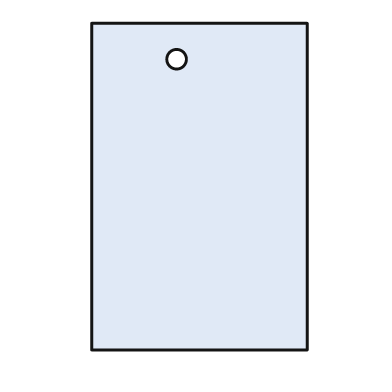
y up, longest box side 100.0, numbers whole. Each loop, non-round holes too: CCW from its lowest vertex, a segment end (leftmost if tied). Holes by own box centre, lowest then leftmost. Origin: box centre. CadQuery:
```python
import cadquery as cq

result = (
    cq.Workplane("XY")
    .moveTo(-33.0, -50.0)
    .lineTo(33.0, -50.0)
    .lineTo(33.0, 50.0)
    .lineTo(-33.0, 50.0)
    .close()
    .moveTo(-7.0, 39.0)
    .circle(3.0)
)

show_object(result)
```